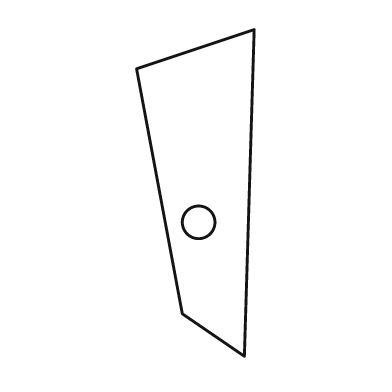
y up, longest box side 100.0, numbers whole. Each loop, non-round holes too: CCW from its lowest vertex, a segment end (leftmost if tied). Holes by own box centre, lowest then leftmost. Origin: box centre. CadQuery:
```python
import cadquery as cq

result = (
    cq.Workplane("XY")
    .moveTo(15.0, -50.0)
    .lineTo(18.0, 50.0)
    .lineTo(-18.0, 38.0)
    .lineTo(-4.0, -37.0)
    .close()
    .moveTo(1.0, -9.0)
    .circle(5.0)
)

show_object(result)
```